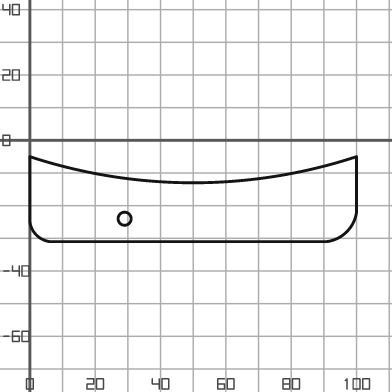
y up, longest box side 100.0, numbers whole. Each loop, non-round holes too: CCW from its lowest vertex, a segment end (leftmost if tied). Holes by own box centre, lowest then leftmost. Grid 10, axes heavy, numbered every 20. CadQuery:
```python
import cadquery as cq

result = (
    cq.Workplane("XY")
    .moveTo(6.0, -31.0)
    .lineTo(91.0, -31.0)
    .threePointArc((97.0, -28.0), (100.0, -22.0))
    .lineTo(100.0, -5.0)
    .threePointArc((50.0, -13.0), (0.0, -5.0))
    .lineTo(0.0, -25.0)
    .threePointArc((2.0, -29.0), (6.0, -31.0))
    .close()
    .moveTo(29.0, -24.0)
    .circle(2.0)
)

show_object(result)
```